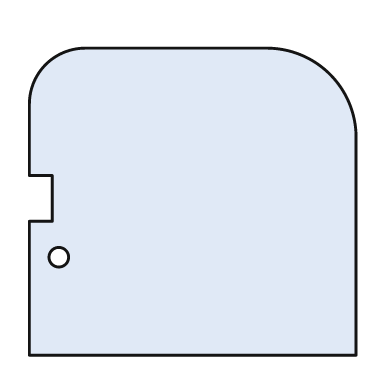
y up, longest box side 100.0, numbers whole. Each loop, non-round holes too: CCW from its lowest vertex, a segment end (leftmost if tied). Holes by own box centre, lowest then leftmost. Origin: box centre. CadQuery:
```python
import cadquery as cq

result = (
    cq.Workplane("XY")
    .moveTo(-50.0, -47.0)
    .lineTo(50.0, -47.0)
    .lineTo(50.0, 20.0)
    .threePointArc((42.0, 39.0), (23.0, 47.0))
    .lineTo(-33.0, 47.0)
    .threePointArc((-45.0, 42.0), (-50.0, 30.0))
    .lineTo(-50.0, 8.0)
    .lineTo(-43.0, 8.0)
    .lineTo(-43.0, -6.0)
    .lineTo(-50.0, -6.0)
    .close()
    .moveTo(-41.0, -17.0)
    .circle(3.0)
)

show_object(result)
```